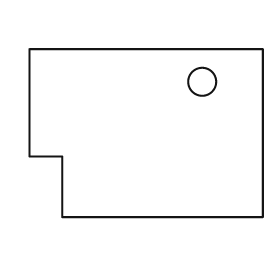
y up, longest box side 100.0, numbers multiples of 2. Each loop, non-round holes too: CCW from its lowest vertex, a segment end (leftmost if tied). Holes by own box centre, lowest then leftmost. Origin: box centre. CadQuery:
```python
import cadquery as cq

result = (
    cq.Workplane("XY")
    .moveTo(-36.0, -36.0)
    .lineTo(50.0, -36.0)
    .lineTo(50.0, 36.0)
    .lineTo(-50.0, 36.0)
    .lineTo(-50.0, -10.0)
    .lineTo(-36.0, -10.0)
    .close()
    .moveTo(24.0, 22.0)
    .circle(6.0)
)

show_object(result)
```